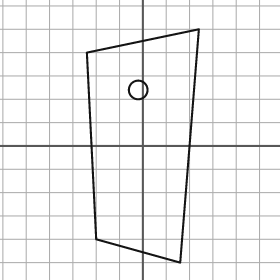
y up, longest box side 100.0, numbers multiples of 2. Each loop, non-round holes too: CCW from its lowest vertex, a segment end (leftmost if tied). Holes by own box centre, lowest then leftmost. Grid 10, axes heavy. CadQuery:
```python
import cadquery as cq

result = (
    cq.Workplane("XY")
    .moveTo(16.0, -50.0)
    .lineTo(24.0, 50.0)
    .lineTo(-24.0, 40.0)
    .lineTo(-20.0, -40.0)
    .close()
    .moveTo(-2.0, 24.0)
    .circle(4.0)
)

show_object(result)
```